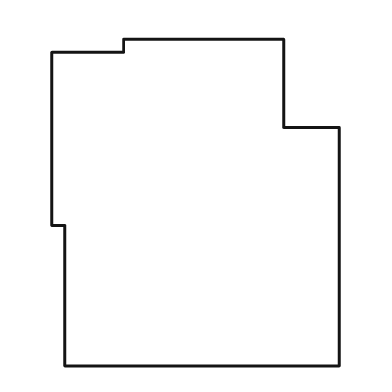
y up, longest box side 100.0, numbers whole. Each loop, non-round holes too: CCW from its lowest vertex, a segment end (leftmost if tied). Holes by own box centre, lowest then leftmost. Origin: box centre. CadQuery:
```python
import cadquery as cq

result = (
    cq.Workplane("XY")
    .moveTo(-40.0, -50.0)
    .lineTo(44.0, -50.0)
    .lineTo(44.0, 23.0)
    .lineTo(27.0, 23.0)
    .lineTo(27.0, 50.0)
    .lineTo(-22.0, 50.0)
    .lineTo(-22.0, 46.0)
    .lineTo(-44.0, 46.0)
    .lineTo(-44.0, -7.0)
    .lineTo(-40.0, -7.0)
    .close()
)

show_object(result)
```